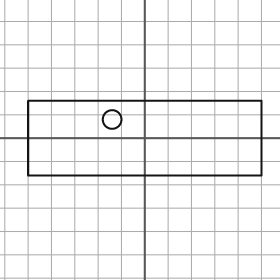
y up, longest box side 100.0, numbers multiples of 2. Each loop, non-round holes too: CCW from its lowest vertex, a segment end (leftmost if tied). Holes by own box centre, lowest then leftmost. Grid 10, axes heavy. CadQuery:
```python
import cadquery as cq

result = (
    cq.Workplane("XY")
    .moveTo(-50.0, -16.0)
    .lineTo(50.0, -16.0)
    .lineTo(50.0, 16.0)
    .lineTo(-50.0, 16.0)
    .close()
    .moveTo(-14.0, 8.0)
    .circle(4.0)
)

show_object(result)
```